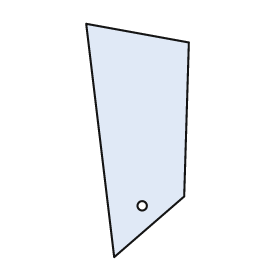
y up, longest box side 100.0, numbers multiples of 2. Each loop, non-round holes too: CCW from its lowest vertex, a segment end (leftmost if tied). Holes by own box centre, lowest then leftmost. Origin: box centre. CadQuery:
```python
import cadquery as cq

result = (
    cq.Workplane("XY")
    .moveTo(-10.0, -50.0)
    .lineTo(20.0, -24.0)
    .lineTo(22.0, 42.0)
    .lineTo(-22.0, 50.0)
    .close()
    .moveTo(2.0, -28.0)
    .circle(2.0)
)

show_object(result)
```